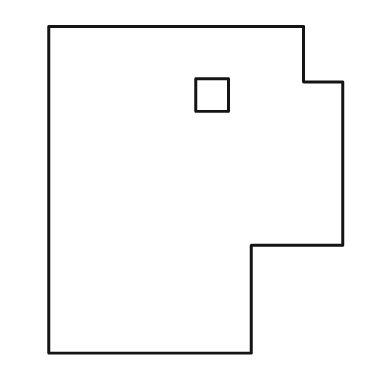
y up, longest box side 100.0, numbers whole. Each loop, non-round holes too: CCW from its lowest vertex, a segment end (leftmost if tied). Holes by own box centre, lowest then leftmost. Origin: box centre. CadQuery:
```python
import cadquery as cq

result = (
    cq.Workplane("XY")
    .moveTo(-45.0, -50.0)
    .lineTo(17.0, -50.0)
    .lineTo(17.0, -17.0)
    .lineTo(45.0, -17.0)
    .lineTo(45.0, 33.0)
    .lineTo(33.0, 33.0)
    .lineTo(33.0, 50.0)
    .lineTo(-45.0, 50.0)
    .close()
    .moveTo(0.0, 24.0)
    .lineTo(10.0, 24.0)
    .lineTo(10.0, 34.0)
    .lineTo(0.0, 34.0)
    .close()
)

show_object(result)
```